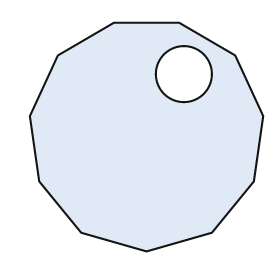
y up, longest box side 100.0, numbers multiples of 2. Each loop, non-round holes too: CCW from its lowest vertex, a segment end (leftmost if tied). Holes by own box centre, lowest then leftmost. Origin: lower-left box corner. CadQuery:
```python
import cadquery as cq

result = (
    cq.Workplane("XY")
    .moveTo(50.0, 0.0)
    .lineTo(78.0, 8.0)
    .lineTo(96.0, 30.0)
    .lineTo(100.0, 58.0)
    .lineTo(88.0, 84.0)
    .lineTo(64.0, 98.0)
    .lineTo(36.0, 98.0)
    .lineTo(12.0, 84.0)
    .lineTo(0.0, 58.0)
    .lineTo(4.0, 30.0)
    .lineTo(22.0, 8.0)
    .close()
    .moveTo(66.0, 76.0)
    .circle(12.0)
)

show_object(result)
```